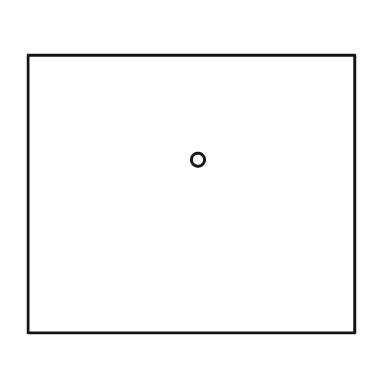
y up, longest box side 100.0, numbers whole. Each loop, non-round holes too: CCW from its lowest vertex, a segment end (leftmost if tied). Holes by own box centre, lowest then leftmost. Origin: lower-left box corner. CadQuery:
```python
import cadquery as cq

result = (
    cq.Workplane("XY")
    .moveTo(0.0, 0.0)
    .lineTo(100.0, 0.0)
    .lineTo(100.0, 85.0)
    .lineTo(0.0, 85.0)
    .close()
    .moveTo(52.0, 53.0)
    .circle(2.0)
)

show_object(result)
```